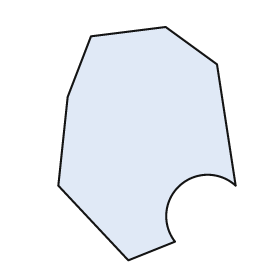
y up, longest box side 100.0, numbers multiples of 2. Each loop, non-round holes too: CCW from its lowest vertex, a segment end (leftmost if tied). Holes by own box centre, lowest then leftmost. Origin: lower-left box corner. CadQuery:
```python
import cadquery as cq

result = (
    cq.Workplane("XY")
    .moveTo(30.0, 0.0)
    .lineTo(50.0, 8.0)
    .threePointArc((52.0, 32.0), (76.0, 32.0))
    .lineTo(68.0, 84.0)
    .lineTo(46.0, 100.0)
    .lineTo(14.0, 96.0)
    .lineTo(4.0, 70.0)
    .lineTo(0.0, 32.0)
    .close()
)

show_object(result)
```